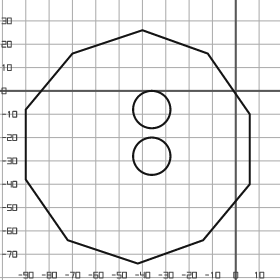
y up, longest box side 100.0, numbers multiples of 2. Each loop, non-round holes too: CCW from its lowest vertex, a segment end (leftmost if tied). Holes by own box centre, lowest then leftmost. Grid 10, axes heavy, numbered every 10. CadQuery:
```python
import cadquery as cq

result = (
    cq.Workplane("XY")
    .moveTo(-42.0, -74.0)
    .lineTo(-14.0, -64.0)
    .lineTo(6.0, -40.0)
    .lineTo(6.0, -10.0)
    .lineTo(-12.0, 16.0)
    .lineTo(-40.0, 26.0)
    .lineTo(-70.0, 16.0)
    .lineTo(-90.0, -8.0)
    .lineTo(-90.0, -38.0)
    .lineTo(-72.0, -64.0)
    .close()
    .moveTo(-36.0, -28.0)
    .circle(8.0)
    .moveTo(-36.0, -8.0)
    .circle(8.0)
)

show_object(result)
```